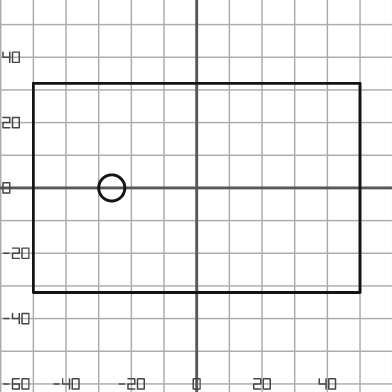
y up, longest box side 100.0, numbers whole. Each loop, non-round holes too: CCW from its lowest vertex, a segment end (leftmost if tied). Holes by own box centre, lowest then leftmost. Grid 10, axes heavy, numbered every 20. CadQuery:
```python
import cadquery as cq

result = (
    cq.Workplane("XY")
    .moveTo(-50.0, -32.0)
    .lineTo(50.0, -32.0)
    .lineTo(50.0, 32.0)
    .lineTo(-50.0, 32.0)
    .close()
    .moveTo(-26.0, 0.0)
    .circle(4.0)
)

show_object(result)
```